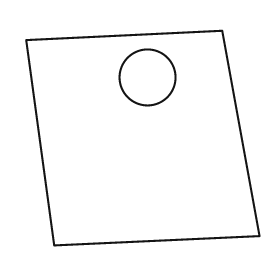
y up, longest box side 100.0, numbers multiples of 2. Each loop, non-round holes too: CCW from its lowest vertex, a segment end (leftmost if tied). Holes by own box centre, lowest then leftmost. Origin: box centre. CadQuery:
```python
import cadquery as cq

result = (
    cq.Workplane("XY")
    .moveTo(-38.0, -46.0)
    .lineTo(50.0, -42.0)
    .lineTo(34.0, 46.0)
    .lineTo(-50.0, 42.0)
    .close()
    .moveTo(2.0, 26.0)
    .circle(12.0)
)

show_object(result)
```